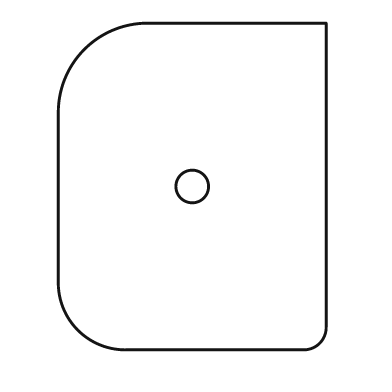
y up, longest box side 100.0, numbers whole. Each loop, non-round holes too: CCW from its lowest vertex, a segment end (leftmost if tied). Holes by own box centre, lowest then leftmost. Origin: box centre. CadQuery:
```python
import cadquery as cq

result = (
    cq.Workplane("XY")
    .moveTo(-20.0, -50.0)
    .lineTo(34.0, -50.0)
    .threePointArc((39.0, -48.0), (41.0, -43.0))
    .lineTo(41.0, 50.0)
    .lineTo(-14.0, 50.0)
    .threePointArc((-33.0, 42.0), (-41.0, 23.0))
    .lineTo(-41.0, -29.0)
    .threePointArc((-35.0, -44.0), (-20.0, -50.0))
    .close()
    .moveTo(0.0, 0.0)
    .circle(5.0)
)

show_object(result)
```